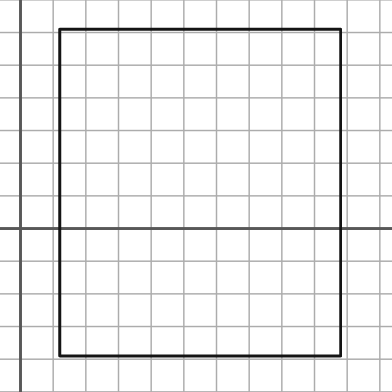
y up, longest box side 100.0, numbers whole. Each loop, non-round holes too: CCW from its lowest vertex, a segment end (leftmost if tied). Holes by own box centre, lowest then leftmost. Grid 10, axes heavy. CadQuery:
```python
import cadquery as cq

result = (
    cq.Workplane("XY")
    .moveTo(12.0, -39.0)
    .lineTo(98.0, -39.0)
    .lineTo(98.0, 61.0)
    .lineTo(12.0, 61.0)
    .close()
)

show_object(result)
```